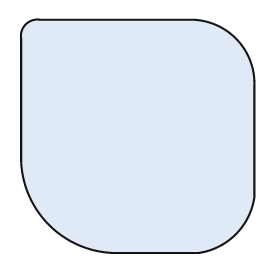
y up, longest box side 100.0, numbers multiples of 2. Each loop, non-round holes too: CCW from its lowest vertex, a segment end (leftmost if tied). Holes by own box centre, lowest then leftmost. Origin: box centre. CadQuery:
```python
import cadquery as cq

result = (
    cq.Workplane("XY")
    .moveTo(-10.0, -50.0)
    .lineTo(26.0, -50.0)
    .threePointArc((42.0, -42.0), (50.0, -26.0))
    .lineTo(50.0, 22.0)
    .threePointArc((42.0, 42.0), (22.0, 50.0))
    .lineTo(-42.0, 50.0)
    .threePointArc((-48.0, 48.0), (-50.0, 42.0))
    .lineTo(-50.0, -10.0)
    .threePointArc((-38.0, -38.0), (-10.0, -50.0))
    .close()
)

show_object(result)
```